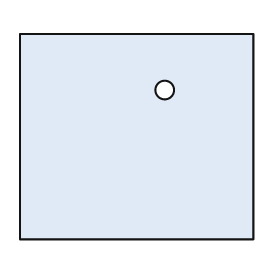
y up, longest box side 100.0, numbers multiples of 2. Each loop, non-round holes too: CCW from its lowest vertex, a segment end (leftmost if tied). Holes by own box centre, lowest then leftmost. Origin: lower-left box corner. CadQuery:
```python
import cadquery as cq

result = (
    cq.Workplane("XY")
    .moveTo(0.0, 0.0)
    .lineTo(100.0, 0.0)
    .lineTo(100.0, 88.0)
    .lineTo(0.0, 88.0)
    .close()
    .moveTo(62.0, 64.0)
    .circle(4.0)
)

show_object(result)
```